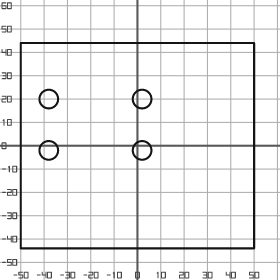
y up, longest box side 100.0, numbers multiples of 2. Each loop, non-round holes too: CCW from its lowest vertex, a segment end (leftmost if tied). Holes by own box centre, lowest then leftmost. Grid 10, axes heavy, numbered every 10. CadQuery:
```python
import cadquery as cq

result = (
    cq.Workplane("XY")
    .moveTo(-50.0, -44.0)
    .lineTo(50.0, -44.0)
    .lineTo(50.0, 44.0)
    .lineTo(-50.0, 44.0)
    .close()
    .moveTo(-38.0, -2.0)
    .circle(4.0)
    .moveTo(2.0, -2.0)
    .circle(4.0)
    .moveTo(-38.0, 20.0)
    .circle(4.0)
    .moveTo(2.0, 20.0)
    .circle(4.0)
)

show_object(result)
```